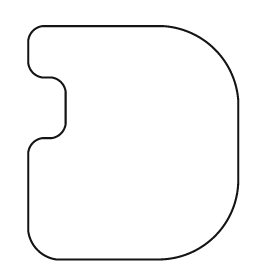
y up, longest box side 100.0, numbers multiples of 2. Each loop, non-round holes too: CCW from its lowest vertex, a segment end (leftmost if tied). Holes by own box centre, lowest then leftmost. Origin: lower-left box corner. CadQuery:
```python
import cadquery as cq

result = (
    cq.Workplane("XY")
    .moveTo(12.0, 0.0)
    .lineTo(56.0, 0.0)
    .threePointArc((80.0, 10.0), (90.0, 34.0))
    .lineTo(90.0, 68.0)
    .threePointArc((80.0, 90.0), (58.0, 100.0))
    .lineTo(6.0, 100.0)
    .threePointArc((2.0, 98.0), (0.0, 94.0))
    .lineTo(0.0, 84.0)
    .threePointArc((2.0, 80.0), (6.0, 78.0))
    .lineTo(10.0, 78.0)
    .threePointArc((14.0, 76.0), (16.0, 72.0))
    .lineTo(16.0, 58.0)
    .threePointArc((14.0, 54.0), (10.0, 52.0))
    .lineTo(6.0, 52.0)
    .threePointArc((2.0, 50.0), (0.0, 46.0))
    .lineTo(0.0, 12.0)
    .threePointArc((4.0, 4.0), (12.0, 0.0))
    .close()
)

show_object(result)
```